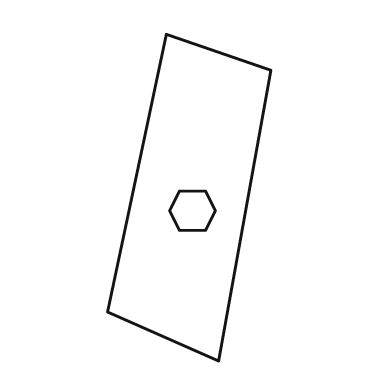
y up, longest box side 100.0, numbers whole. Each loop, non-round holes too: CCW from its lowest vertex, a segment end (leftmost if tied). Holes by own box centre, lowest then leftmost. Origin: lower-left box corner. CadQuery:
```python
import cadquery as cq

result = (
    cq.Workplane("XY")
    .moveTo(34.0, 0.0)
    .lineTo(50.0, 89.0)
    .lineTo(18.0, 100.0)
    .lineTo(0.0, 15.0)
    .close()
    .moveTo(22.0, 40.0)
    .lineTo(30.0, 40.0)
    .lineTo(33.0, 46.0)
    .lineTo(30.0, 52.0)
    .lineTo(22.0, 52.0)
    .lineTo(19.0, 46.0)
    .close()
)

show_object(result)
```